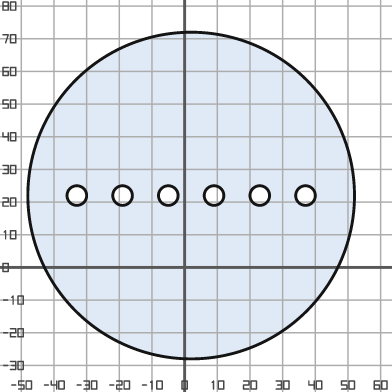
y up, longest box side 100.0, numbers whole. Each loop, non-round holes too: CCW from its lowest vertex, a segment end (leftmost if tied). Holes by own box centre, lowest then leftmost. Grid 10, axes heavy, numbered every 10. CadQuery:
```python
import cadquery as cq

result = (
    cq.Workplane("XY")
    .moveTo(2.0, 22.0)
    .circle(50.0)
    .moveTo(-33.0, 22.0)
    .circle(3.0)
    .moveTo(-19.0, 22.0)
    .circle(3.0)
    .moveTo(-5.0, 22.0)
    .circle(3.0)
    .moveTo(9.0, 22.0)
    .circle(3.0)
    .moveTo(23.0, 22.0)
    .circle(3.0)
    .moveTo(37.0, 22.0)
    .circle(3.0)
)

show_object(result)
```